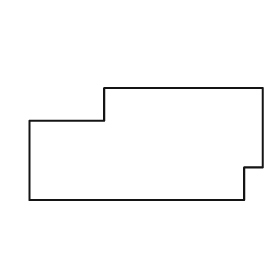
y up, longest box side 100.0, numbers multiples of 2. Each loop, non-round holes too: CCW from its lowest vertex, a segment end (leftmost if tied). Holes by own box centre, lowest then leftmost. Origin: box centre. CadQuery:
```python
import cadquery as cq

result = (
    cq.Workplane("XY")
    .moveTo(-50.0, -24.0)
    .lineTo(42.0, -24.0)
    .lineTo(42.0, -10.0)
    .lineTo(50.0, -10.0)
    .lineTo(50.0, 24.0)
    .lineTo(-18.0, 24.0)
    .lineTo(-18.0, 10.0)
    .lineTo(-50.0, 10.0)
    .close()
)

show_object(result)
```